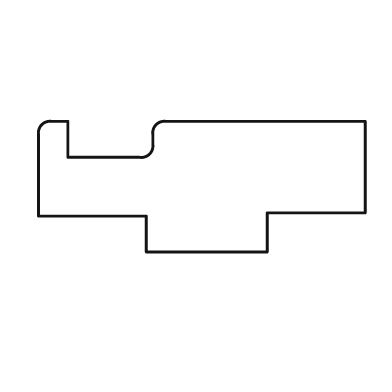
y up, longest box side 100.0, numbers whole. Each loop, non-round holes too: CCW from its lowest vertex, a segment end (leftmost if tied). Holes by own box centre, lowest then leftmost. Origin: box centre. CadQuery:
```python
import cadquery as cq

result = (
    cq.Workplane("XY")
    .moveTo(-17.0, -20.0)
    .lineTo(20.0, -20.0)
    .lineTo(20.0, -8.0)
    .lineTo(50.0, -8.0)
    .lineTo(50.0, 20.0)
    .lineTo(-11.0, 20.0)
    .threePointArc((-14.0, 19.0), (-15.0, 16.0))
    .lineTo(-15.0, 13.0)
    .threePointArc((-16.0, 10.0), (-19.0, 9.0))
    .lineTo(-41.0, 9.0)
    .lineTo(-41.0, 20.0)
    .lineTo(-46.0, 20.0)
    .threePointArc((-49.0, 19.0), (-50.0, 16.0))
    .lineTo(-50.0, -9.0)
    .lineTo(-17.0, -9.0)
    .close()
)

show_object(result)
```